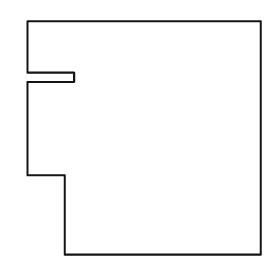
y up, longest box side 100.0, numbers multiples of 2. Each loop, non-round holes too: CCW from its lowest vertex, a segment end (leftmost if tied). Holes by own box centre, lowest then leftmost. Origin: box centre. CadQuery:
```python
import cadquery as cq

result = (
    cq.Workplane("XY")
    .moveTo(-34.0, -50.0)
    .lineTo(50.0, -50.0)
    .lineTo(50.0, 50.0)
    .lineTo(-50.0, 50.0)
    .lineTo(-50.0, 28.0)
    .lineTo(-30.0, 28.0)
    .lineTo(-30.0, 24.0)
    .lineTo(-50.0, 24.0)
    .lineTo(-50.0, -16.0)
    .lineTo(-34.0, -16.0)
    .close()
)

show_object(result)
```